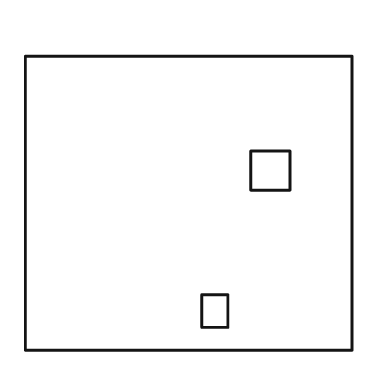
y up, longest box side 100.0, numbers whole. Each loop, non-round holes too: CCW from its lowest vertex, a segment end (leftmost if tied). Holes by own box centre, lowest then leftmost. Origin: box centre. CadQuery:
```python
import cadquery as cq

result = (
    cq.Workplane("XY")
    .moveTo(-50.0, -45.0)
    .lineTo(50.0, -45.0)
    .lineTo(50.0, 45.0)
    .lineTo(-50.0, 45.0)
    .close()
    .moveTo(4.0, -38.0)
    .lineTo(12.0, -38.0)
    .lineTo(12.0, -28.0)
    .lineTo(4.0, -28.0)
    .close()
    .moveTo(19.0, 4.0)
    .lineTo(31.0, 4.0)
    .lineTo(31.0, 16.0)
    .lineTo(19.0, 16.0)
    .close()
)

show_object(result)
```